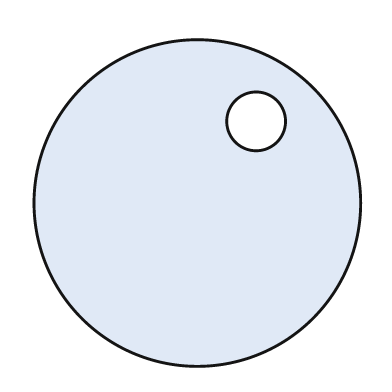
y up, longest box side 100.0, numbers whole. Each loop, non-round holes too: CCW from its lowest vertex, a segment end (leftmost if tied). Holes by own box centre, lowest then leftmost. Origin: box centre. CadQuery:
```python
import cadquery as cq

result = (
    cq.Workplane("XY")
    .moveTo(0.0, 0.0)
    .circle(50.0)
    .moveTo(18.0, 25.0)
    .circle(9.0)
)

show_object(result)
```